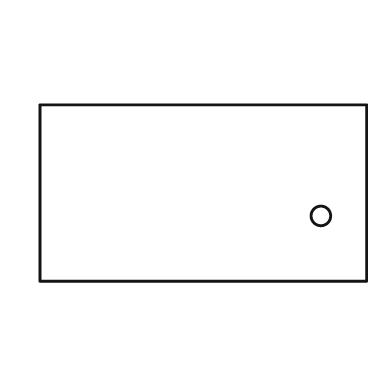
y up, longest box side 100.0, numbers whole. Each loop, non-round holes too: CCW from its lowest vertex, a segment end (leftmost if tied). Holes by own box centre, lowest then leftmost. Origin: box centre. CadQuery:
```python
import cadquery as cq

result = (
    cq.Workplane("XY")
    .moveTo(-50.0, -27.0)
    .lineTo(50.0, -27.0)
    .lineTo(50.0, 27.0)
    .lineTo(-50.0, 27.0)
    .close()
    .moveTo(36.0, -7.0)
    .circle(3.0)
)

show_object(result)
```